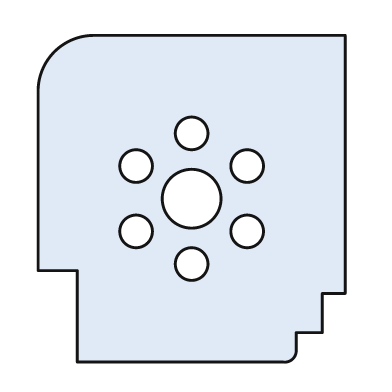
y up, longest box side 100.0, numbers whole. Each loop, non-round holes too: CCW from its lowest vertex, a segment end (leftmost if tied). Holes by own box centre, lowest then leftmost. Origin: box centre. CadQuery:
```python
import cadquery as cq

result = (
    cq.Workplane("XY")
    .moveTo(-35.0, -50.0)
    .lineTo(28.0, -50.0)
    .threePointArc((31.0, -49.0), (32.0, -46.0))
    .lineTo(32.0, -41.0)
    .lineTo(40.0, -41.0)
    .lineTo(40.0, -29.0)
    .lineTo(47.0, -29.0)
    .lineTo(47.0, 50.0)
    .lineTo(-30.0, 50.0)
    .threePointArc((-42.0, 45.0), (-47.0, 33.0))
    .lineTo(-47.0, -22.0)
    .lineTo(-35.0, -22.0)
    .close()
    .moveTo(0.0, -20.0)
    .circle(5.0)
    .moveTo(-17.0, -10.0)
    .circle(5.0)
    .moveTo(17.0, -10.0)
    .circle(5.0)
    .moveTo(0.0, 0.0)
    .circle(9.0)
    .moveTo(-17.0, 10.0)
    .circle(5.0)
    .moveTo(17.0, 10.0)
    .circle(5.0)
    .moveTo(0.0, 20.0)
    .circle(5.0)
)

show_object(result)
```